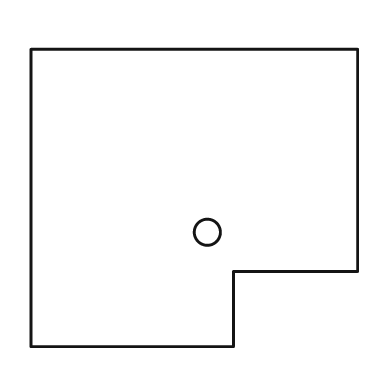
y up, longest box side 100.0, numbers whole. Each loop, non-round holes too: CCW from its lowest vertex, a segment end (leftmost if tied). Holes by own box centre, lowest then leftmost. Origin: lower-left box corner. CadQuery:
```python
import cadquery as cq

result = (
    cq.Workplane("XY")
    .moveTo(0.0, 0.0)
    .lineTo(62.0, 0.0)
    .lineTo(62.0, 23.0)
    .lineTo(100.0, 23.0)
    .lineTo(100.0, 91.0)
    .lineTo(0.0, 91.0)
    .close()
    .moveTo(54.0, 35.0)
    .circle(4.0)
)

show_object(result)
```